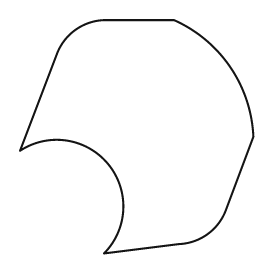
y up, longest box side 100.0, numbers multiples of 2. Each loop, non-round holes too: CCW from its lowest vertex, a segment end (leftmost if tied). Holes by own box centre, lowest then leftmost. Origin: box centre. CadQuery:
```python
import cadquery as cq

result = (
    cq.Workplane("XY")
    .moveTo(-14.0, -50.0)
    .lineTo(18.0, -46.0)
    .threePointArc((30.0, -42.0), (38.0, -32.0))
    .lineTo(50.0, 0.0)
    .threePointArc((40.0, 30.0), (16.0, 50.0))
    .lineTo(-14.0, 50.0)
    .threePointArc((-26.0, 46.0), (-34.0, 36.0))
    .lineTo(-50.0, -6.0)
    .threePointArc((-12.0, -12.0), (-14.0, -50.0))
    .close()
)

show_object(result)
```